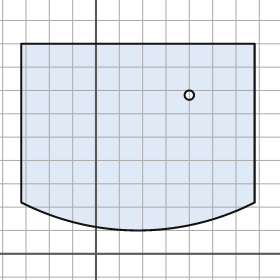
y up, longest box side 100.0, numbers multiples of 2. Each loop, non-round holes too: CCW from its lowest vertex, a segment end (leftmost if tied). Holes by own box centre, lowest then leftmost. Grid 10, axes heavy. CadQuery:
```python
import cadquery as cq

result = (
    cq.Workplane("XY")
    .moveTo(-32.0, 22.0)
    .threePointArc((18.0, 10.0), (68.0, 22.0))
    .lineTo(68.0, 90.0)
    .lineTo(-32.0, 90.0)
    .close()
    .moveTo(40.0, 68.0)
    .circle(2.0)
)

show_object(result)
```